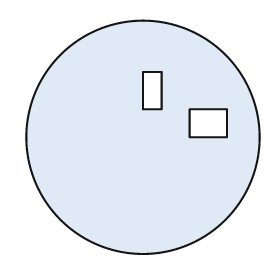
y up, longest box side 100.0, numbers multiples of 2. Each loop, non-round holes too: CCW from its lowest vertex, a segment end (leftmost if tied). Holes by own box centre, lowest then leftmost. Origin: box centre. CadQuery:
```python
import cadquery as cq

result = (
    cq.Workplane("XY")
    .moveTo(0.0, 0.0)
    .circle(50.0)
    .moveTo(20.0, 0.0)
    .lineTo(36.0, 0.0)
    .lineTo(36.0, 12.0)
    .lineTo(20.0, 12.0)
    .close()
    .moveTo(0.0, 12.0)
    .lineTo(8.0, 12.0)
    .lineTo(8.0, 28.0)
    .lineTo(0.0, 28.0)
    .close()
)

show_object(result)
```